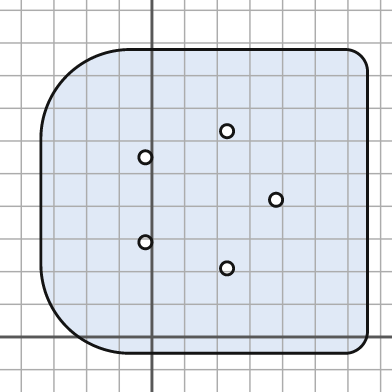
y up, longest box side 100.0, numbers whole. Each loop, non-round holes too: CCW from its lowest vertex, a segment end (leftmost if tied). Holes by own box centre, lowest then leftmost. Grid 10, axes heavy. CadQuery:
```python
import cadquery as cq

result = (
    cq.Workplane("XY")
    .moveTo(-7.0, -5.0)
    .lineTo(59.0, -5.0)
    .threePointArc((64.0, -3.0), (66.0, 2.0))
    .lineTo(66.0, 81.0)
    .threePointArc((64.0, 86.0), (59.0, 88.0))
    .lineTo(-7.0, 88.0)
    .threePointArc((-26.0, 80.0), (-34.0, 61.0))
    .lineTo(-34.0, 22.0)
    .threePointArc((-26.0, 3.0), (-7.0, -5.0))
    .close()
    .moveTo(23.0, 21.0)
    .circle(2.0)
    .moveTo(-2.0, 29.0)
    .circle(2.0)
    .moveTo(38.0, 42.0)
    .circle(2.0)
    .moveTo(-2.0, 55.0)
    .circle(2.0)
    .moveTo(23.0, 63.0)
    .circle(2.0)
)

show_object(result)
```